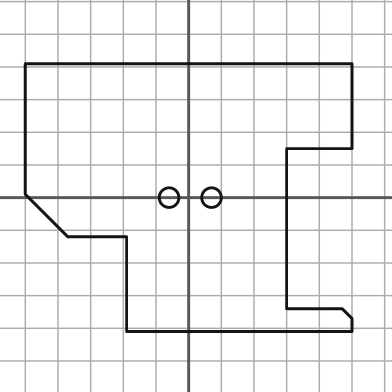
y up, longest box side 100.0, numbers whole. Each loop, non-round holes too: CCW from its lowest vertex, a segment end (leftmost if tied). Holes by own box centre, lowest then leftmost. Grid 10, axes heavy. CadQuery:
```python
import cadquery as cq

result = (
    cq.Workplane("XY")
    .moveTo(-19.0, -41.0)
    .lineTo(50.0, -41.0)
    .lineTo(50.0, -37.0)
    .lineTo(47.0, -34.0)
    .lineTo(30.0, -34.0)
    .lineTo(30.0, 15.0)
    .lineTo(50.0, 15.0)
    .lineTo(50.0, 41.0)
    .lineTo(-50.0, 41.0)
    .lineTo(-50.0, 1.0)
    .lineTo(-37.0, -12.0)
    .lineTo(-19.0, -12.0)
    .close()
    .moveTo(-6.0, 0.0)
    .circle(3.0)
    .moveTo(7.0, 0.0)
    .circle(3.0)
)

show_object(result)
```